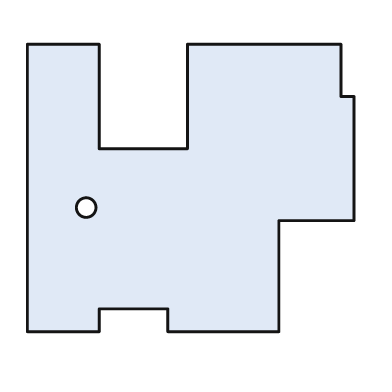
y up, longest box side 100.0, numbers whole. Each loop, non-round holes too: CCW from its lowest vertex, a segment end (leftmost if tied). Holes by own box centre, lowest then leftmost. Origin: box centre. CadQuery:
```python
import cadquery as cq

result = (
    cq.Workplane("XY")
    .moveTo(-50.0, -44.0)
    .lineTo(-28.0, -44.0)
    .lineTo(-28.0, -37.0)
    .lineTo(-7.0, -37.0)
    .lineTo(-7.0, -44.0)
    .lineTo(27.0, -44.0)
    .lineTo(27.0, -10.0)
    .lineTo(50.0, -10.0)
    .lineTo(50.0, 28.0)
    .lineTo(46.0, 28.0)
    .lineTo(46.0, 44.0)
    .lineTo(-1.0, 44.0)
    .lineTo(-1.0, 12.0)
    .lineTo(-28.0, 12.0)
    .lineTo(-28.0, 44.0)
    .lineTo(-50.0, 44.0)
    .close()
    .moveTo(-32.0, -6.0)
    .circle(3.0)
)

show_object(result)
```